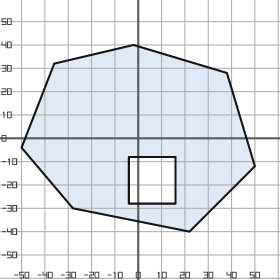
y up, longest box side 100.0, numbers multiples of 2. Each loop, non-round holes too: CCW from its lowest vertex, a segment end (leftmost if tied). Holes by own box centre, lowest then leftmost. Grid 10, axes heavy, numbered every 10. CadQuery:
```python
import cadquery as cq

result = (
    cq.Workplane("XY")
    .moveTo(22.0, -40.0)
    .lineTo(50.0, -12.0)
    .lineTo(38.0, 28.0)
    .lineTo(-2.0, 40.0)
    .lineTo(-36.0, 32.0)
    .lineTo(-50.0, -4.0)
    .lineTo(-28.0, -30.0)
    .close()
    .moveTo(-4.0, -28.0)
    .lineTo(16.0, -28.0)
    .lineTo(16.0, -8.0)
    .lineTo(-4.0, -8.0)
    .close()
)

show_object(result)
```